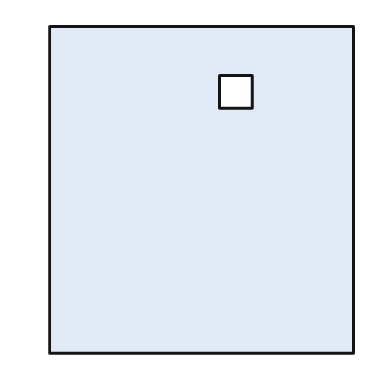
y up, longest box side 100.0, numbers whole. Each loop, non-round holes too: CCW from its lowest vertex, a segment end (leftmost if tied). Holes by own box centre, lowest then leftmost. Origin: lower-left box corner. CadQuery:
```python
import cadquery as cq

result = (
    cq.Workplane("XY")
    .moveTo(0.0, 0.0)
    .lineTo(93.0, 0.0)
    .lineTo(93.0, 100.0)
    .lineTo(0.0, 100.0)
    .close()
    .moveTo(52.0, 75.0)
    .lineTo(62.0, 75.0)
    .lineTo(62.0, 85.0)
    .lineTo(52.0, 85.0)
    .close()
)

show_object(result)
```